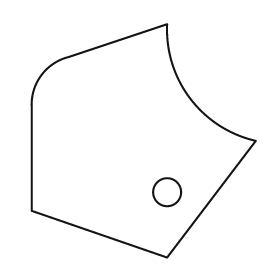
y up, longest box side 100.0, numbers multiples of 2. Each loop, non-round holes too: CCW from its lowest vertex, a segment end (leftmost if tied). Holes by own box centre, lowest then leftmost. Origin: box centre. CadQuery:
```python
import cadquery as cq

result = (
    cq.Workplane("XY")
    .moveTo(10.0, -50.0)
    .lineTo(48.0, 0.0)
    .threePointArc((20.0, 18.0), (10.0, 50.0))
    .lineTo(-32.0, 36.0)
    .threePointArc((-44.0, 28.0), (-48.0, 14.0))
    .lineTo(-48.0, -30.0)
    .close()
    .moveTo(10.0, -22.0)
    .circle(6.0)
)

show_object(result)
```